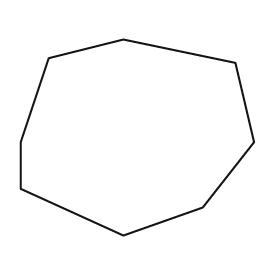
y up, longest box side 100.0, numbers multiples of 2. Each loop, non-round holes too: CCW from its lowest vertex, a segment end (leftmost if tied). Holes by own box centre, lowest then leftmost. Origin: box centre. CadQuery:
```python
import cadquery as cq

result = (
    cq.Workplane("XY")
    .moveTo(-6.0, -42.0)
    .lineTo(28.0, -30.0)
    .lineTo(50.0, -2.0)
    .lineTo(42.0, 32.0)
    .lineTo(-6.0, 42.0)
    .lineTo(-38.0, 34.0)
    .lineTo(-50.0, -2.0)
    .lineTo(-50.0, -22.0)
    .close()
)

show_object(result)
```